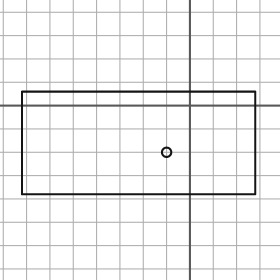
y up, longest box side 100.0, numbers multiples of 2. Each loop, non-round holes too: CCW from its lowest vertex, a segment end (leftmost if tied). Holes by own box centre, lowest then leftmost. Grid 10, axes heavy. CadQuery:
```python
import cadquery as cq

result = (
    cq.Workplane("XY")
    .moveTo(-72.0, -38.0)
    .lineTo(28.0, -38.0)
    .lineTo(28.0, 6.0)
    .lineTo(-72.0, 6.0)
    .close()
    .moveTo(-10.0, -20.0)
    .circle(2.0)
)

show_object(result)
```